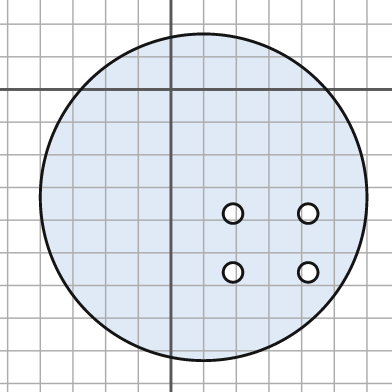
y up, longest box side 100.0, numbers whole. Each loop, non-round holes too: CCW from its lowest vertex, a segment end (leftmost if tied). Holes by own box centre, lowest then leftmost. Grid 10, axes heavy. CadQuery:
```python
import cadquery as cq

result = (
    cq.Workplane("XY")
    .moveTo(10.0, -33.0)
    .circle(50.0)
    .moveTo(19.0, -56.0)
    .circle(3.0)
    .moveTo(42.0, -56.0)
    .circle(3.0)
    .moveTo(19.0, -38.0)
    .circle(3.0)
    .moveTo(42.0, -38.0)
    .circle(3.0)
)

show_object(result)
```